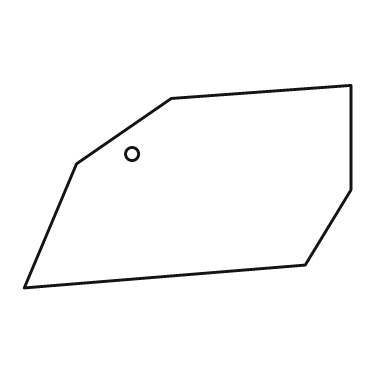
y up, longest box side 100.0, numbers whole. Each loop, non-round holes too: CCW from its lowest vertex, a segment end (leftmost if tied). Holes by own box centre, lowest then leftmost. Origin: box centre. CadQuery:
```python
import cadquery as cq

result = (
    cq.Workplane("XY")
    .moveTo(-50.0, -31.0)
    .lineTo(36.0, -24.0)
    .lineTo(50.0, -1.0)
    .lineTo(50.0, 31.0)
    .lineTo(-5.0, 27.0)
    .lineTo(-34.0, 7.0)
    .close()
    .moveTo(-17.0, 10.0)
    .circle(2.0)
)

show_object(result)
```